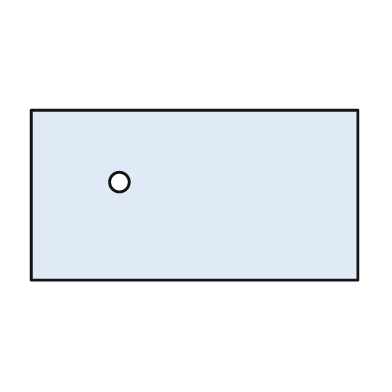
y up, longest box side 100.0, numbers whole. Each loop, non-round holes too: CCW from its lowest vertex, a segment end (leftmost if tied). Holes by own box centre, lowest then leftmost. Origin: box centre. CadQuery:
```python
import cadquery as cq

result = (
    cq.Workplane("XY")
    .moveTo(-50.0, -26.0)
    .lineTo(50.0, -26.0)
    .lineTo(50.0, 26.0)
    .lineTo(-50.0, 26.0)
    .close()
    .moveTo(-23.0, 4.0)
    .circle(3.0)
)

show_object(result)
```